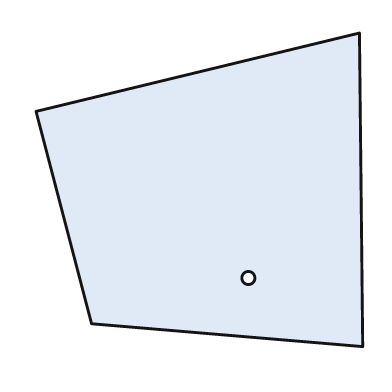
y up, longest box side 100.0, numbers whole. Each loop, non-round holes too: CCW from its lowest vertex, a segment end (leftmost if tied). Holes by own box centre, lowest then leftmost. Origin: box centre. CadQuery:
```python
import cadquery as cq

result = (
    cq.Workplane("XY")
    .moveTo(50.0, -48.0)
    .lineTo(49.0, 48.0)
    .lineTo(-50.0, 24.0)
    .lineTo(-33.0, -41.0)
    .close()
    .moveTo(15.0, -27.0)
    .circle(2.0)
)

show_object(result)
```